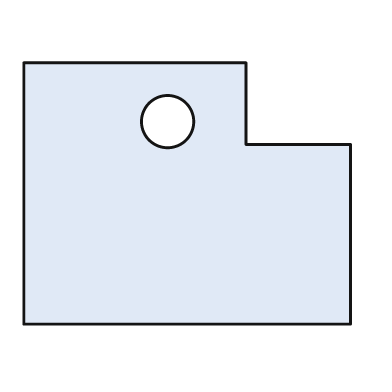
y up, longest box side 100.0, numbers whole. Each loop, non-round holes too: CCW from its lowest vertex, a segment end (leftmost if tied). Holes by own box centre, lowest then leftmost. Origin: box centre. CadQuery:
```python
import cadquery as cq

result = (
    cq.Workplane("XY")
    .moveTo(-50.0, -40.0)
    .lineTo(50.0, -40.0)
    .lineTo(50.0, 15.0)
    .lineTo(18.0, 15.0)
    .lineTo(18.0, 40.0)
    .lineTo(-50.0, 40.0)
    .close()
    .moveTo(-6.0, 22.0)
    .circle(8.0)
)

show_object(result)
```